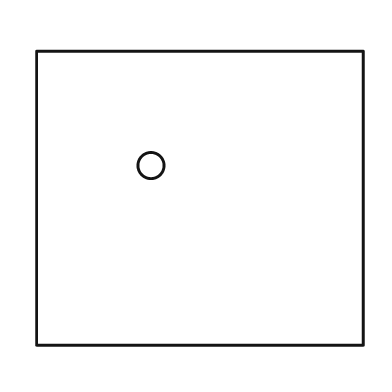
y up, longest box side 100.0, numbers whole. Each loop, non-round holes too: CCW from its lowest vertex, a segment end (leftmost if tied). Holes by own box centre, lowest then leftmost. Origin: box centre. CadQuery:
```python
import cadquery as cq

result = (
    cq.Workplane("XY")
    .moveTo(-50.0, -45.0)
    .lineTo(50.0, -45.0)
    .lineTo(50.0, 45.0)
    .lineTo(-50.0, 45.0)
    .close()
    .moveTo(-15.0, 10.0)
    .circle(4.0)
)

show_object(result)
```